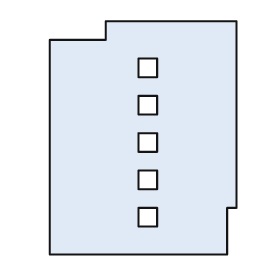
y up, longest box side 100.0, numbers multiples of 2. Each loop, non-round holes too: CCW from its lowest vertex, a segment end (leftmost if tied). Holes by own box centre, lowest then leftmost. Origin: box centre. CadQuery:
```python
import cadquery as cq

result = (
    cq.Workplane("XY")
    .moveTo(-40.0, -50.0)
    .lineTo(36.0, -50.0)
    .lineTo(36.0, -30.0)
    .lineTo(40.0, -30.0)
    .lineTo(40.0, 50.0)
    .lineTo(-16.0, 50.0)
    .lineTo(-16.0, 42.0)
    .lineTo(-40.0, 42.0)
    .close()
    .moveTo(-2.0, -38.0)
    .lineTo(6.0, -38.0)
    .lineTo(6.0, -30.0)
    .lineTo(-2.0, -30.0)
    .close()
    .moveTo(-2.0, -22.0)
    .lineTo(6.0, -22.0)
    .lineTo(6.0, -14.0)
    .lineTo(-2.0, -14.0)
    .close()
    .moveTo(-2.0, -6.0)
    .lineTo(6.0, -6.0)
    .lineTo(6.0, 2.0)
    .lineTo(-2.0, 2.0)
    .close()
    .moveTo(-2.0, 10.0)
    .lineTo(6.0, 10.0)
    .lineTo(6.0, 18.0)
    .lineTo(-2.0, 18.0)
    .close()
    .moveTo(-2.0, 26.0)
    .lineTo(6.0, 26.0)
    .lineTo(6.0, 34.0)
    .lineTo(-2.0, 34.0)
    .close()
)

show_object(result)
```